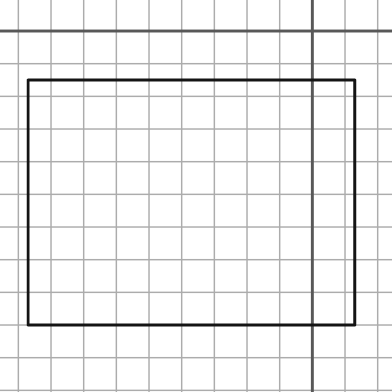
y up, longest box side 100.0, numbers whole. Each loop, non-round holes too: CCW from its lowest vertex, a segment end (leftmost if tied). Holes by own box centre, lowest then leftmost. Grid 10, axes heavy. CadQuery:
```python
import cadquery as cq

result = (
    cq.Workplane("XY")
    .moveTo(-87.0, -90.0)
    .lineTo(13.0, -90.0)
    .lineTo(13.0, -15.0)
    .lineTo(-87.0, -15.0)
    .close()
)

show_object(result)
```